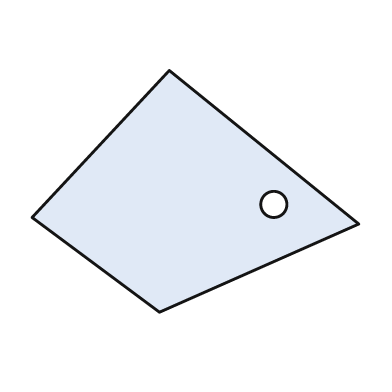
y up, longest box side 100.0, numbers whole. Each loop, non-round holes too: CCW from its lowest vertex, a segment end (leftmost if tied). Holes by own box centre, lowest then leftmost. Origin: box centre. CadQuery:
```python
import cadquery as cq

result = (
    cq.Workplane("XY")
    .moveTo(-11.0, -37.0)
    .lineTo(50.0, -10.0)
    .lineTo(-8.0, 37.0)
    .lineTo(-50.0, -8.0)
    .close()
    .moveTo(24.0, -4.0)
    .circle(4.0)
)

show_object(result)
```